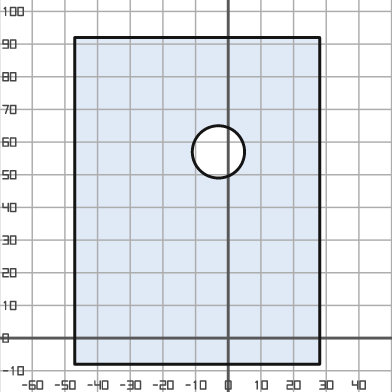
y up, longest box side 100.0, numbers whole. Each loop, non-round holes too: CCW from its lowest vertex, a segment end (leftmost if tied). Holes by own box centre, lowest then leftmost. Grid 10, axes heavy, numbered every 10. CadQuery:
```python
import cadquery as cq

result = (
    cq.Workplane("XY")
    .moveTo(-47.0, -8.0)
    .lineTo(28.0, -8.0)
    .lineTo(28.0, 92.0)
    .lineTo(-47.0, 92.0)
    .close()
    .moveTo(-3.0, 57.0)
    .circle(8.0)
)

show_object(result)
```